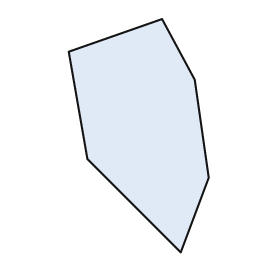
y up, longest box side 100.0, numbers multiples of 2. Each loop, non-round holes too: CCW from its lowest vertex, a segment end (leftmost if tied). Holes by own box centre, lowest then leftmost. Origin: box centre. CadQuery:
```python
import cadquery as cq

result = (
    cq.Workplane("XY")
    .moveTo(18.0, -50.0)
    .lineTo(30.0, -18.0)
    .lineTo(24.0, 24.0)
    .lineTo(10.0, 50.0)
    .lineTo(-30.0, 36.0)
    .lineTo(-22.0, -10.0)
    .close()
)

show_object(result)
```